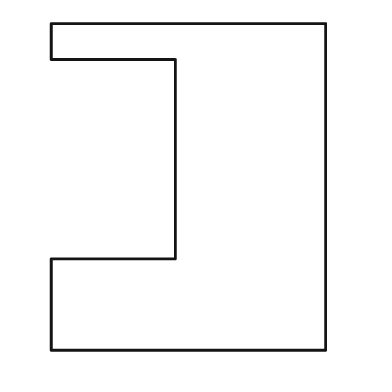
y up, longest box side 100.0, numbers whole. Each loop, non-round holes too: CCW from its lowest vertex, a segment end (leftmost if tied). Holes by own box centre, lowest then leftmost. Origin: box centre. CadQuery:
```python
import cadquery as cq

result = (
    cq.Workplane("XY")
    .moveTo(-42.0, -50.0)
    .lineTo(42.0, -50.0)
    .lineTo(42.0, 50.0)
    .lineTo(-42.0, 50.0)
    .lineTo(-42.0, 39.0)
    .lineTo(-4.0, 39.0)
    .lineTo(-4.0, -22.0)
    .lineTo(-42.0, -22.0)
    .close()
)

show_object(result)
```